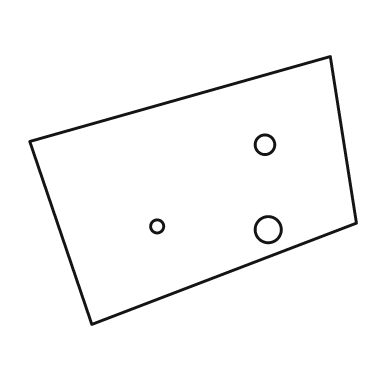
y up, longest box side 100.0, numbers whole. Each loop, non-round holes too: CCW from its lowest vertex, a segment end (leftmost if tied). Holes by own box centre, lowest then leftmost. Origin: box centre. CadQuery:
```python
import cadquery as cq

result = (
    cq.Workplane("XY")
    .moveTo(-31.0, -41.0)
    .lineTo(50.0, -10.0)
    .lineTo(42.0, 41.0)
    .lineTo(-50.0, 15.0)
    .close()
    .moveTo(23.0, -12.0)
    .circle(4.0)
    .moveTo(-11.0, -11.0)
    .circle(2.0)
    .moveTo(22.0, 14.0)
    .circle(3.0)
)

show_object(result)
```